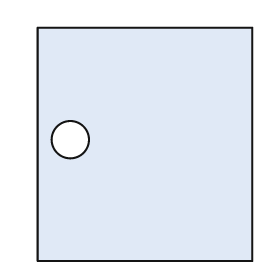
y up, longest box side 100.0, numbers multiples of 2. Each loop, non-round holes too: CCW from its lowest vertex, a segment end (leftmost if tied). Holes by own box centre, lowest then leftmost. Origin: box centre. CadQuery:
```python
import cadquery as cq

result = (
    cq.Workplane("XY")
    .moveTo(-46.0, -50.0)
    .lineTo(46.0, -50.0)
    .lineTo(46.0, 50.0)
    .lineTo(-46.0, 50.0)
    .close()
    .moveTo(-32.0, 2.0)
    .circle(8.0)
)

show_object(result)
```